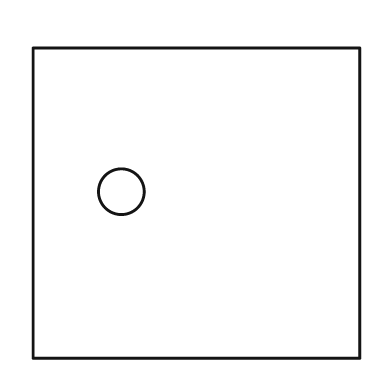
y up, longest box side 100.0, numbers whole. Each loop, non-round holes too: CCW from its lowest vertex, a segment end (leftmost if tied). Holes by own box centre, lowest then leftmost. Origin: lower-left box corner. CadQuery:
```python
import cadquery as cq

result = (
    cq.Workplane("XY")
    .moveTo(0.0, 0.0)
    .lineTo(100.0, 0.0)
    .lineTo(100.0, 95.0)
    .lineTo(0.0, 95.0)
    .close()
    .moveTo(27.0, 51.0)
    .circle(7.0)
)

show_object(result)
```